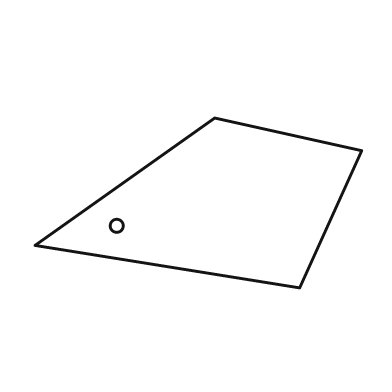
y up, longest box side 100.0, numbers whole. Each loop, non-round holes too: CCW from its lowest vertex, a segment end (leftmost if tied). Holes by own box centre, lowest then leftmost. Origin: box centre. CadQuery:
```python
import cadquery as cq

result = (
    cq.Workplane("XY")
    .moveTo(31.0, -26.0)
    .lineTo(50.0, 16.0)
    .lineTo(5.0, 26.0)
    .lineTo(-50.0, -13.0)
    .close()
    .moveTo(-25.0, -7.0)
    .circle(2.0)
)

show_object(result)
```